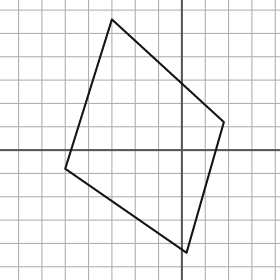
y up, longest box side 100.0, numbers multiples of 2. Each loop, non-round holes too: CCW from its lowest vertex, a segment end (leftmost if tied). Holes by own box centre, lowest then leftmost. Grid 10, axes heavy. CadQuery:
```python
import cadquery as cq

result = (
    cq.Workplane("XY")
    .moveTo(2.0, -44.0)
    .lineTo(18.0, 12.0)
    .lineTo(-30.0, 56.0)
    .lineTo(-50.0, -8.0)
    .close()
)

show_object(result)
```